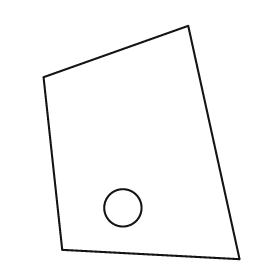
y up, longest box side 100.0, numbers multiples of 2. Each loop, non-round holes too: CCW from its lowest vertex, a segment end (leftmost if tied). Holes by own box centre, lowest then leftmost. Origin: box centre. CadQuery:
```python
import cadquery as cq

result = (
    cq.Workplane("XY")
    .moveTo(42.0, -50.0)
    .lineTo(20.0, 50.0)
    .lineTo(-42.0, 28.0)
    .lineTo(-34.0, -46.0)
    .close()
    .moveTo(-8.0, -28.0)
    .circle(8.0)
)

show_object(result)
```